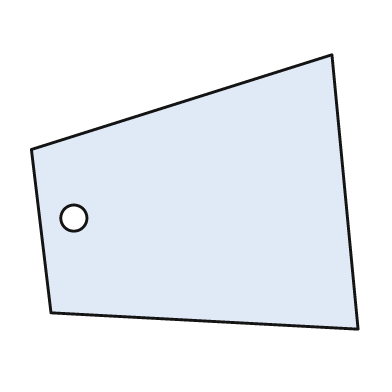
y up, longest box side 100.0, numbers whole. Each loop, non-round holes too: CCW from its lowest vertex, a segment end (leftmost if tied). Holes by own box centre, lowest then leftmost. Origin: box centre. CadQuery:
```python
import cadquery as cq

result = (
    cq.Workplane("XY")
    .moveTo(50.0, -42.0)
    .lineTo(42.0, 42.0)
    .lineTo(-50.0, 13.0)
    .lineTo(-44.0, -37.0)
    .close()
    .moveTo(-37.0, -8.0)
    .circle(4.0)
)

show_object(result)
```